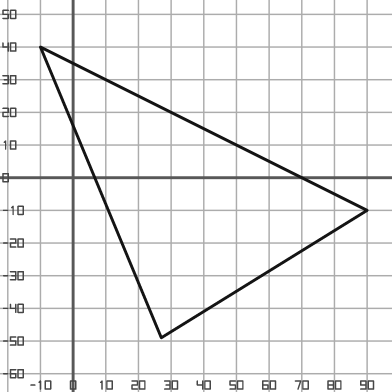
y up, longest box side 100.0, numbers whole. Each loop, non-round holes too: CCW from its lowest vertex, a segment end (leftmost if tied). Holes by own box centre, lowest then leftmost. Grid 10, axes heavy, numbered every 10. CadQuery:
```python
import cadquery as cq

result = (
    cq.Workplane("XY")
    .moveTo(27.0, -49.0)
    .lineTo(90.0, -10.0)
    .lineTo(-10.0, 40.0)
    .close()
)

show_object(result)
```